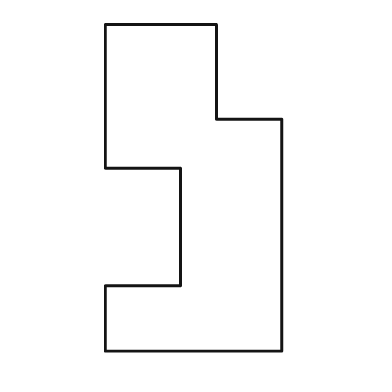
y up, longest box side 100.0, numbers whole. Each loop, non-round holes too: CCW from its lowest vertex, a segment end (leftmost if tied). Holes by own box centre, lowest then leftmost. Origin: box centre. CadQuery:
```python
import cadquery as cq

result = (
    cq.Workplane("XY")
    .moveTo(-27.0, -50.0)
    .lineTo(27.0, -50.0)
    .lineTo(27.0, 21.0)
    .lineTo(7.0, 21.0)
    .lineTo(7.0, 50.0)
    .lineTo(-27.0, 50.0)
    .lineTo(-27.0, 6.0)
    .lineTo(-4.0, 6.0)
    .lineTo(-4.0, -30.0)
    .lineTo(-27.0, -30.0)
    .close()
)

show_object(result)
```